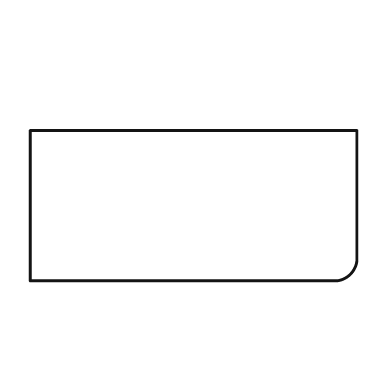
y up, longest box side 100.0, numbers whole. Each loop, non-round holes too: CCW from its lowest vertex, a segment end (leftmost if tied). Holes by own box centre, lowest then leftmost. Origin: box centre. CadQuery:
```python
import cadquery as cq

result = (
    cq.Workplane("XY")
    .moveTo(-50.0, -23.0)
    .lineTo(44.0, -23.0)
    .threePointArc((48.0, -21.0), (50.0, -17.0))
    .lineTo(50.0, 23.0)
    .lineTo(-50.0, 23.0)
    .close()
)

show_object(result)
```